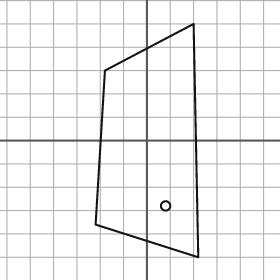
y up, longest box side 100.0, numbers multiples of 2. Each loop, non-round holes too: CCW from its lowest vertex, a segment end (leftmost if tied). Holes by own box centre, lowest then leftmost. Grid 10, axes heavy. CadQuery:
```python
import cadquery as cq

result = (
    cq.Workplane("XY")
    .moveTo(22.0, -50.0)
    .lineTo(20.0, 50.0)
    .lineTo(-18.0, 30.0)
    .lineTo(-22.0, -36.0)
    .close()
    .moveTo(8.0, -28.0)
    .circle(2.0)
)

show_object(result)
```